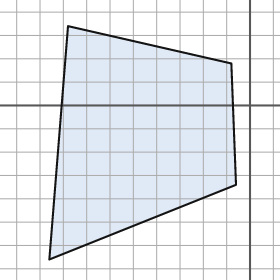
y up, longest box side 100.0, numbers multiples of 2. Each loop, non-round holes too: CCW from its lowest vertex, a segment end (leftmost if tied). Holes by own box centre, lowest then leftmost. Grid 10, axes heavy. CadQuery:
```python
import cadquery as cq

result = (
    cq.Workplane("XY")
    .moveTo(-86.0, -66.0)
    .lineTo(-6.0, -34.0)
    .lineTo(-8.0, 18.0)
    .lineTo(-78.0, 34.0)
    .close()
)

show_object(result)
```